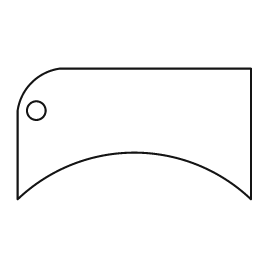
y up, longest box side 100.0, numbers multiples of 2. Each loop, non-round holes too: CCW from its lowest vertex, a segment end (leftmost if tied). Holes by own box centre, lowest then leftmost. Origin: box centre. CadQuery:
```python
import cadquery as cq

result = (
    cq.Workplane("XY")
    .moveTo(-50.0, -28.0)
    .threePointArc((0.0, -8.0), (50.0, -28.0))
    .lineTo(50.0, 28.0)
    .lineTo(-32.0, 28.0)
    .threePointArc((-44.0, 22.0), (-50.0, 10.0))
    .close()
    .moveTo(-42.0, 10.0)
    .circle(4.0)
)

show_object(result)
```